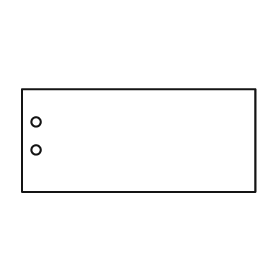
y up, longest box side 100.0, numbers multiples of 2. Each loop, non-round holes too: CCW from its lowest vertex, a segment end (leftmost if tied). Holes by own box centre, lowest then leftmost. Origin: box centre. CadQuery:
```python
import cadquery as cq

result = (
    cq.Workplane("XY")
    .moveTo(-50.0, -22.0)
    .lineTo(50.0, -22.0)
    .lineTo(50.0, 22.0)
    .lineTo(-50.0, 22.0)
    .close()
    .moveTo(-44.0, -4.0)
    .circle(2.0)
    .moveTo(-44.0, 8.0)
    .circle(2.0)
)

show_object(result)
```